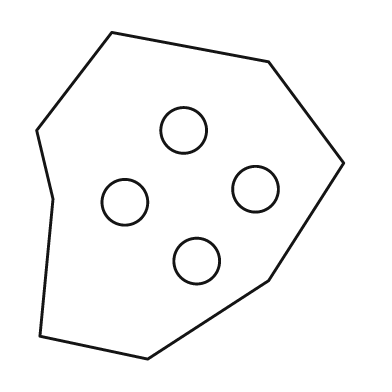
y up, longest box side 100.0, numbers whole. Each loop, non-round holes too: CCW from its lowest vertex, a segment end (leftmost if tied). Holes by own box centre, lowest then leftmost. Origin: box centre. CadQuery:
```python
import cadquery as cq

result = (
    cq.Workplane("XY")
    .moveTo(-13.0, -50.0)
    .lineTo(24.0, -26.0)
    .lineTo(47.0, 10.0)
    .lineTo(24.0, 41.0)
    .lineTo(-24.0, 50.0)
    .lineTo(-47.0, 20.0)
    .lineTo(-42.0, -1.0)
    .lineTo(-46.0, -43.0)
    .close()
    .moveTo(2.0, -20.0)
    .circle(7.0)
    .moveTo(-20.0, -2.0)
    .circle(7.0)
    .moveTo(20.0, 2.0)
    .circle(7.0)
    .moveTo(-2.0, 20.0)
    .circle(7.0)
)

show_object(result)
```